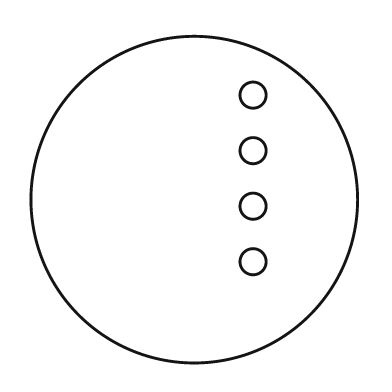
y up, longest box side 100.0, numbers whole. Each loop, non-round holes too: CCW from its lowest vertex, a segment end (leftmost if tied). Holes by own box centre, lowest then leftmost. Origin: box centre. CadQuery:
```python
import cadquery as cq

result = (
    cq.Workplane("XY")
    .moveTo(0.0, 0.0)
    .circle(50.0)
    .moveTo(18.0, -19.0)
    .circle(4.0)
    .moveTo(18.0, -2.0)
    .circle(4.0)
    .moveTo(18.0, 15.0)
    .circle(4.0)
    .moveTo(18.0, 32.0)
    .circle(4.0)
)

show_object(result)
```